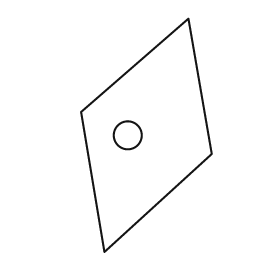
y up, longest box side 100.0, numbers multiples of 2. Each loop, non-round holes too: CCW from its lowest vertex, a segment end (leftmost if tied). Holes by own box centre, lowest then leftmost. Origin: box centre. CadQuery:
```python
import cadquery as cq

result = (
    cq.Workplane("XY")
    .moveTo(-18.0, -50.0)
    .lineTo(28.0, -8.0)
    .lineTo(18.0, 50.0)
    .lineTo(-28.0, 10.0)
    .close()
    .moveTo(-8.0, 0.0)
    .circle(6.0)
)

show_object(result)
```